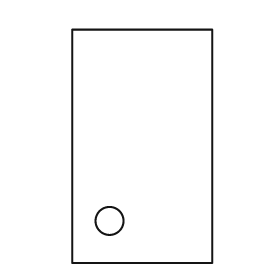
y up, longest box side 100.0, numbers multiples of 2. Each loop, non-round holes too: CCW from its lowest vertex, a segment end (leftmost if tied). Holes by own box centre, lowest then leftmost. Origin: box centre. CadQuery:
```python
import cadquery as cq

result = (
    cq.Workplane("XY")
    .moveTo(-30.0, -50.0)
    .lineTo(30.0, -50.0)
    .lineTo(30.0, 50.0)
    .lineTo(-30.0, 50.0)
    .close()
    .moveTo(-14.0, -32.0)
    .circle(6.0)
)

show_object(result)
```